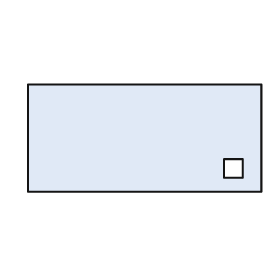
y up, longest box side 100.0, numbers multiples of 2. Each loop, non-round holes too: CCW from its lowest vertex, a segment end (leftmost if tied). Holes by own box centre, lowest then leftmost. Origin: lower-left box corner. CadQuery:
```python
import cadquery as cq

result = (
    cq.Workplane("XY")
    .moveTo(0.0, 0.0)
    .lineTo(100.0, 0.0)
    .lineTo(100.0, 46.0)
    .lineTo(0.0, 46.0)
    .close()
    .moveTo(84.0, 6.0)
    .lineTo(92.0, 6.0)
    .lineTo(92.0, 14.0)
    .lineTo(84.0, 14.0)
    .close()
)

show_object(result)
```